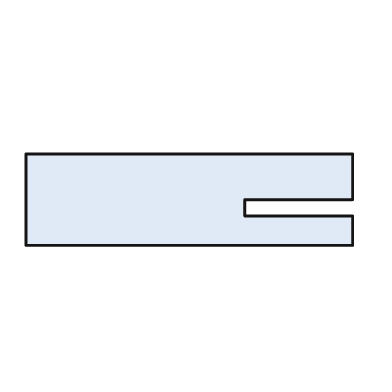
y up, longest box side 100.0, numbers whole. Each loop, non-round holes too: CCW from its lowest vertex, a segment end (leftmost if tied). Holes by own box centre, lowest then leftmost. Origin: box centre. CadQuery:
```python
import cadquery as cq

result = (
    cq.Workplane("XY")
    .moveTo(-50.0, -14.0)
    .lineTo(50.0, -14.0)
    .lineTo(50.0, -5.0)
    .lineTo(17.0, -5.0)
    .lineTo(17.0, 0.0)
    .lineTo(50.0, 0.0)
    .lineTo(50.0, 14.0)
    .lineTo(-50.0, 14.0)
    .close()
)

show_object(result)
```